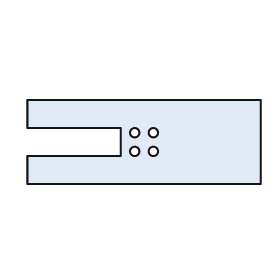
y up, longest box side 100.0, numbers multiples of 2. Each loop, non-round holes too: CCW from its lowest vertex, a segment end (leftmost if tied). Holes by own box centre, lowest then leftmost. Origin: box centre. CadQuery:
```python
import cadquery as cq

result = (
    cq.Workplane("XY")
    .moveTo(-50.0, -18.0)
    .lineTo(50.0, -18.0)
    .lineTo(50.0, 18.0)
    .lineTo(-50.0, 18.0)
    .lineTo(-50.0, 6.0)
    .lineTo(-10.0, 6.0)
    .lineTo(-10.0, -6.0)
    .lineTo(-50.0, -6.0)
    .close()
    .moveTo(-4.0, -4.0)
    .circle(2.0)
    .moveTo(4.0, -4.0)
    .circle(2.0)
    .moveTo(-4.0, 4.0)
    .circle(2.0)
    .moveTo(4.0, 4.0)
    .circle(2.0)
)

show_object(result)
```